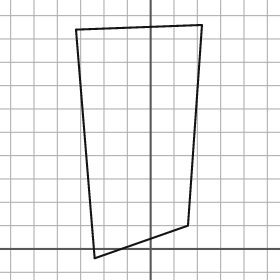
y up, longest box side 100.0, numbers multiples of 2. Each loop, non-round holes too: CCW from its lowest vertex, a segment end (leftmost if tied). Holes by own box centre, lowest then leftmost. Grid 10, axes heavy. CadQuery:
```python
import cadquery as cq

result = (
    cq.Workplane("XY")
    .moveTo(-24.0, -4.0)
    .lineTo(16.0, 10.0)
    .lineTo(22.0, 96.0)
    .lineTo(-32.0, 94.0)
    .close()
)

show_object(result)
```